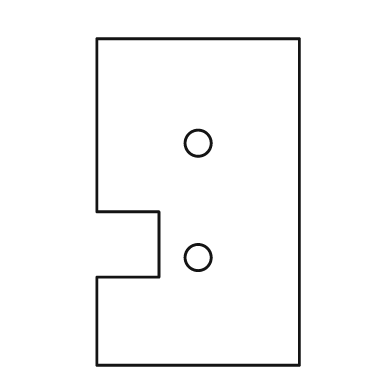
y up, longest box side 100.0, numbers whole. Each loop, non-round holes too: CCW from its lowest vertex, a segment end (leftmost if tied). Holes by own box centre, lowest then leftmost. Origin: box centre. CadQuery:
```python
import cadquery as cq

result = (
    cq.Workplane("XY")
    .moveTo(-31.0, -50.0)
    .lineTo(31.0, -50.0)
    .lineTo(31.0, 50.0)
    .lineTo(-31.0, 50.0)
    .lineTo(-31.0, -3.0)
    .lineTo(-12.0, -3.0)
    .lineTo(-12.0, -23.0)
    .lineTo(-31.0, -23.0)
    .close()
    .moveTo(0.0, -17.0)
    .circle(4.0)
    .moveTo(0.0, 18.0)
    .circle(4.0)
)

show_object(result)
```